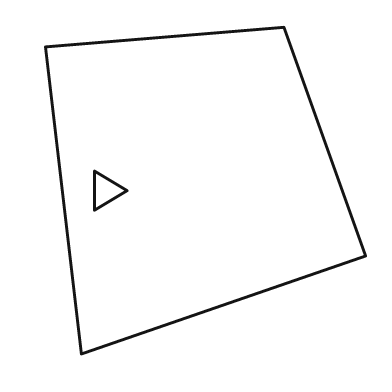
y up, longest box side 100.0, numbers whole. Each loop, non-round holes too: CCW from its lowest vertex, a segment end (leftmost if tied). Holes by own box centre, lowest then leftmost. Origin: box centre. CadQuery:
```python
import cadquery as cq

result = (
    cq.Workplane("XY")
    .moveTo(-38.0, -50.0)
    .lineTo(49.0, -20.0)
    .lineTo(24.0, 50.0)
    .lineTo(-49.0, 44.0)
    .close()
    .moveTo(-34.0, -6.0)
    .lineTo(-24.0, 0.0)
    .lineTo(-34.0, 6.0)
    .close()
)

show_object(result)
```